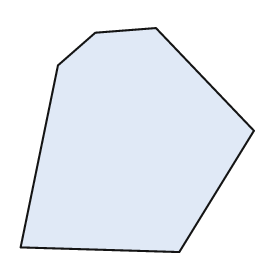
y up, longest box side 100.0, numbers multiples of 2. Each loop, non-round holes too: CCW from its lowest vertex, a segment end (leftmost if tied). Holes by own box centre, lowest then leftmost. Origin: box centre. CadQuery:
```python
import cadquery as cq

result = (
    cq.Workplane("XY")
    .moveTo(18.0, -48.0)
    .lineTo(50.0, 4.0)
    .lineTo(8.0, 48.0)
    .lineTo(-18.0, 46.0)
    .lineTo(-34.0, 32.0)
    .lineTo(-50.0, -46.0)
    .close()
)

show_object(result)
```